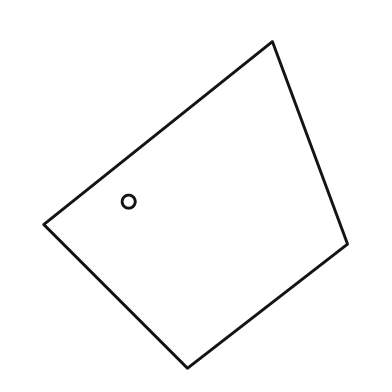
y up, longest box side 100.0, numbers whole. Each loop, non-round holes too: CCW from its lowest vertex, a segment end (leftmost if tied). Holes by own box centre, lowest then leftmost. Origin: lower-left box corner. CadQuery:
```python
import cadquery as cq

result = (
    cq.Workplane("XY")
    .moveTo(44.0, 0.0)
    .lineTo(93.0, 38.0)
    .lineTo(70.0, 100.0)
    .lineTo(0.0, 44.0)
    .close()
    .moveTo(26.0, 51.0)
    .circle(2.0)
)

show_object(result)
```